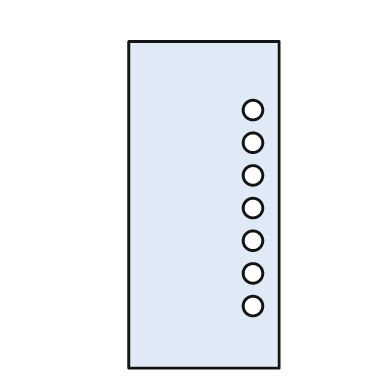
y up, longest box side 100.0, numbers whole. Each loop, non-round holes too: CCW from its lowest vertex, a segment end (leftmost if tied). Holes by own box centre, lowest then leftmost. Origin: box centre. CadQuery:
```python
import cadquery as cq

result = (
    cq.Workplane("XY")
    .moveTo(-23.0, -50.0)
    .lineTo(23.0, -50.0)
    .lineTo(23.0, 50.0)
    .lineTo(-23.0, 50.0)
    .close()
    .moveTo(15.0, -31.0)
    .circle(3.0)
    .moveTo(15.0, -21.0)
    .circle(3.0)
    .moveTo(15.0, -11.0)
    .circle(3.0)
    .moveTo(15.0, -1.0)
    .circle(3.0)
    .moveTo(15.0, 9.0)
    .circle(3.0)
    .moveTo(15.0, 19.0)
    .circle(3.0)
    .moveTo(15.0, 29.0)
    .circle(3.0)
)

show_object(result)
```